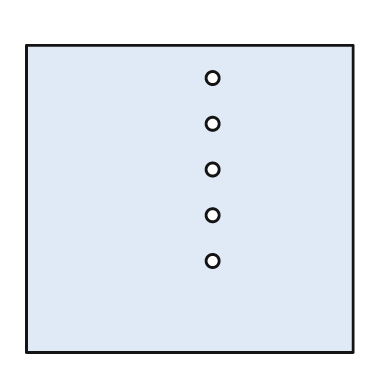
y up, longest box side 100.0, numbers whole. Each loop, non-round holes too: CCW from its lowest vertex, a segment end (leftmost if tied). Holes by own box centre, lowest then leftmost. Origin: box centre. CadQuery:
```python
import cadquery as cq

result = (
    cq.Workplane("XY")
    .moveTo(-50.0, -47.0)
    .lineTo(50.0, -47.0)
    .lineTo(50.0, 47.0)
    .lineTo(-50.0, 47.0)
    .close()
    .moveTo(7.0, -19.0)
    .circle(2.0)
    .moveTo(7.0, -5.0)
    .circle(2.0)
    .moveTo(7.0, 9.0)
    .circle(2.0)
    .moveTo(7.0, 23.0)
    .circle(2.0)
    .moveTo(7.0, 37.0)
    .circle(2.0)
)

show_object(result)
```